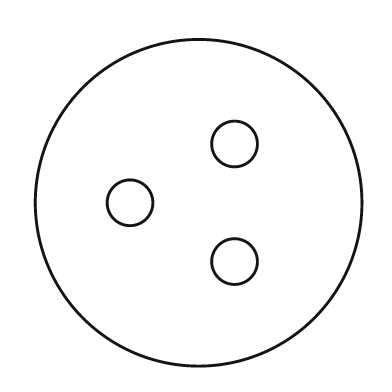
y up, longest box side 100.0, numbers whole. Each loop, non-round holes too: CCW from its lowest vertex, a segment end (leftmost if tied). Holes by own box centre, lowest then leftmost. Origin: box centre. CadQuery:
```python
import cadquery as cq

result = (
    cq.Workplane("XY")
    .moveTo(0.0, 0.0)
    .circle(50.0)
    .moveTo(11.0, -18.0)
    .circle(7.0)
    .moveTo(-21.0, 0.0)
    .circle(7.0)
    .moveTo(11.0, 18.0)
    .circle(7.0)
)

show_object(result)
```